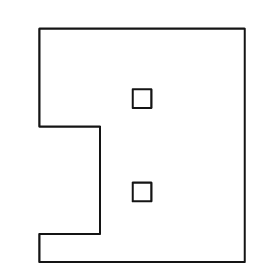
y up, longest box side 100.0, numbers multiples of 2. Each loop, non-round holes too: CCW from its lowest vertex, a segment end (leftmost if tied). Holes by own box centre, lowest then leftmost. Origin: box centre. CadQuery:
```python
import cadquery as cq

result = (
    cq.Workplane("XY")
    .moveTo(-44.0, -50.0)
    .lineTo(44.0, -50.0)
    .lineTo(44.0, 50.0)
    .lineTo(-44.0, 50.0)
    .lineTo(-44.0, 8.0)
    .lineTo(-18.0, 8.0)
    .lineTo(-18.0, -38.0)
    .lineTo(-44.0, -38.0)
    .close()
    .moveTo(-4.0, -24.0)
    .lineTo(4.0, -24.0)
    .lineTo(4.0, -16.0)
    .lineTo(-4.0, -16.0)
    .close()
    .moveTo(-4.0, 16.0)
    .lineTo(4.0, 16.0)
    .lineTo(4.0, 24.0)
    .lineTo(-4.0, 24.0)
    .close()
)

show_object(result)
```